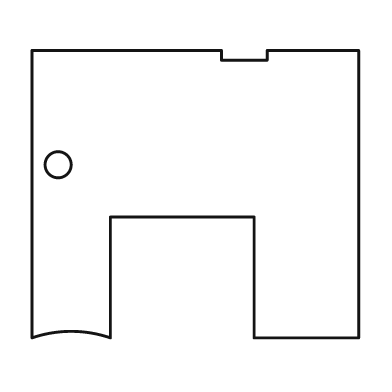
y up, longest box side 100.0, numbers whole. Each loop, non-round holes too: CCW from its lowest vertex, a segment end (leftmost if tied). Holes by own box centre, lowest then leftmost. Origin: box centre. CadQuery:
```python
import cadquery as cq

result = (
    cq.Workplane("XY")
    .moveTo(-50.0, -44.0)
    .threePointArc((-38.0, -42.0), (-26.0, -44.0))
    .lineTo(-26.0, -7.0)
    .lineTo(18.0, -7.0)
    .lineTo(18.0, -44.0)
    .lineTo(50.0, -44.0)
    .lineTo(50.0, 44.0)
    .lineTo(22.0, 44.0)
    .lineTo(22.0, 41.0)
    .lineTo(8.0, 41.0)
    .lineTo(8.0, 44.0)
    .lineTo(-50.0, 44.0)
    .close()
    .moveTo(-42.0, 9.0)
    .circle(4.0)
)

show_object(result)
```